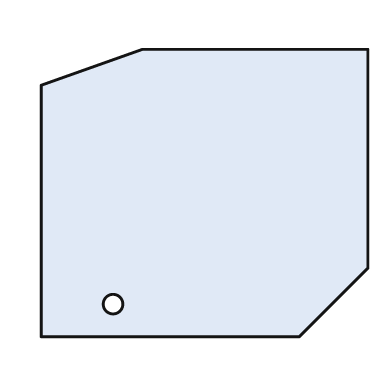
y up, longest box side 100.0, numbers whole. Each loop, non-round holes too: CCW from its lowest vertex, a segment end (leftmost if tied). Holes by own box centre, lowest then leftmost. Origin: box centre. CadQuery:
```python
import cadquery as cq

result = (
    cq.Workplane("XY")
    .moveTo(-50.0, -44.0)
    .lineTo(29.0, -44.0)
    .lineTo(50.0, -23.0)
    .lineTo(50.0, 44.0)
    .lineTo(-19.0, 44.0)
    .lineTo(-50.0, 33.0)
    .close()
    .moveTo(-28.0, -34.0)
    .circle(3.0)
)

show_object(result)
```